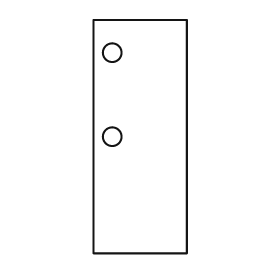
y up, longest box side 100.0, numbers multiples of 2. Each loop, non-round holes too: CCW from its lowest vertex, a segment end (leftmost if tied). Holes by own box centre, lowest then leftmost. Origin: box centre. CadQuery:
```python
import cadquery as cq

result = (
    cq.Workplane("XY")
    .moveTo(-20.0, -50.0)
    .lineTo(20.0, -50.0)
    .lineTo(20.0, 50.0)
    .lineTo(-20.0, 50.0)
    .close()
    .moveTo(-12.0, 0.0)
    .circle(4.0)
    .moveTo(-12.0, 36.0)
    .circle(4.0)
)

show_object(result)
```